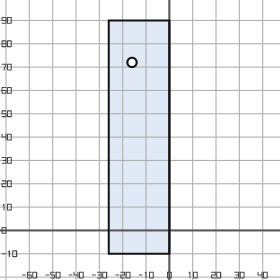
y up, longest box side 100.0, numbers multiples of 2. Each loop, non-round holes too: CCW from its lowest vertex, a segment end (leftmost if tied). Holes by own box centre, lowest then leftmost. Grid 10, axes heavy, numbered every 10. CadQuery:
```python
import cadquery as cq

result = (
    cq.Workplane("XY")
    .moveTo(-26.0, -10.0)
    .lineTo(0.0, -10.0)
    .lineTo(0.0, 90.0)
    .lineTo(-26.0, 90.0)
    .close()
    .moveTo(-16.0, 72.0)
    .circle(2.0)
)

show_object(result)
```